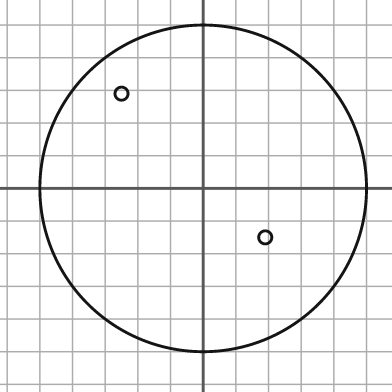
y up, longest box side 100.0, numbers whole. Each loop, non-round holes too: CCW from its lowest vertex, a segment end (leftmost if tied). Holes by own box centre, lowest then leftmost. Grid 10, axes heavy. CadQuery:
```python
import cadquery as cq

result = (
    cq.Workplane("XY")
    .moveTo(0.0, 0.0)
    .circle(50.0)
    .moveTo(19.0, -15.0)
    .circle(2.0)
    .moveTo(-25.0, 29.0)
    .circle(2.0)
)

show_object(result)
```